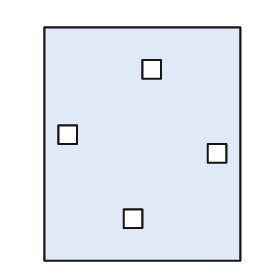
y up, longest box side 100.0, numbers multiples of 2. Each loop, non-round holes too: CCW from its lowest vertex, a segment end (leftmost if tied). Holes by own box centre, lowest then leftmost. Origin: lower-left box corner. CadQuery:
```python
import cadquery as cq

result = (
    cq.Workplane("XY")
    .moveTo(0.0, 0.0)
    .lineTo(84.0, 0.0)
    .lineTo(84.0, 100.0)
    .lineTo(0.0, 100.0)
    .close()
    .moveTo(34.0, 14.0)
    .lineTo(42.0, 14.0)
    .lineTo(42.0, 22.0)
    .lineTo(34.0, 22.0)
    .close()
    .moveTo(70.0, 42.0)
    .lineTo(78.0, 42.0)
    .lineTo(78.0, 50.0)
    .lineTo(70.0, 50.0)
    .close()
    .moveTo(6.0, 50.0)
    .lineTo(14.0, 50.0)
    .lineTo(14.0, 58.0)
    .lineTo(6.0, 58.0)
    .close()
    .moveTo(42.0, 78.0)
    .lineTo(50.0, 78.0)
    .lineTo(50.0, 86.0)
    .lineTo(42.0, 86.0)
    .close()
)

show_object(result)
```